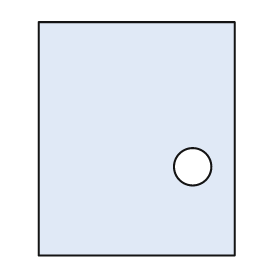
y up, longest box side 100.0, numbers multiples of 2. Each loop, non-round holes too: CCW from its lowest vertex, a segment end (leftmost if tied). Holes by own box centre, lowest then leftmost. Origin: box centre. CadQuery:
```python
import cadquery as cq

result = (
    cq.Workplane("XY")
    .moveTo(-42.0, -50.0)
    .lineTo(42.0, -50.0)
    .lineTo(42.0, 50.0)
    .lineTo(-42.0, 50.0)
    .close()
    .moveTo(24.0, -12.0)
    .circle(8.0)
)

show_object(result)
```